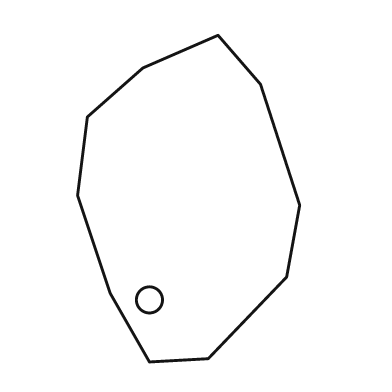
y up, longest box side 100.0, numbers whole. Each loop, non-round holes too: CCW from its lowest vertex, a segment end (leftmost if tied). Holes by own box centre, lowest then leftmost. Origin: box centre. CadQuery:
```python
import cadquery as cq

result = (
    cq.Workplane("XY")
    .moveTo(-12.0, -50.0)
    .lineTo(6.0, -49.0)
    .lineTo(30.0, -24.0)
    .lineTo(34.0, -2.0)
    .lineTo(22.0, 35.0)
    .lineTo(9.0, 50.0)
    .lineTo(-14.0, 40.0)
    .lineTo(-31.0, 25.0)
    .lineTo(-34.0, 1.0)
    .lineTo(-24.0, -29.0)
    .close()
    .moveTo(-12.0, -31.0)
    .circle(4.0)
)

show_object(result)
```